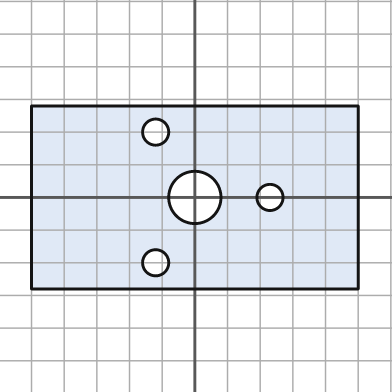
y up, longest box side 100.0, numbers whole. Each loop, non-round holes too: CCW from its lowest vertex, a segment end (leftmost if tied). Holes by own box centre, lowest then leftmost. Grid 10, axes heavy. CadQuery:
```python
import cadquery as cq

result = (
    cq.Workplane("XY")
    .moveTo(-50.0, -28.0)
    .lineTo(50.0, -28.0)
    .lineTo(50.0, 28.0)
    .lineTo(-50.0, 28.0)
    .close()
    .moveTo(-12.0, -20.0)
    .circle(4.0)
    .moveTo(0.0, 0.0)
    .circle(8.0)
    .moveTo(23.0, 0.0)
    .circle(4.0)
    .moveTo(-12.0, 20.0)
    .circle(4.0)
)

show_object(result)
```